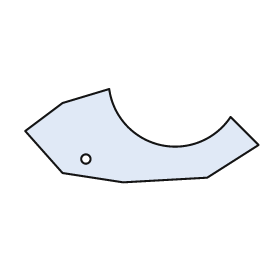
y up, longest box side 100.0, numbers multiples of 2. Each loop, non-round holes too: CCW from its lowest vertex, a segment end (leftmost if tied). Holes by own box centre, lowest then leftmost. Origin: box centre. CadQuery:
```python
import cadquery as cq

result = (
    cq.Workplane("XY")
    .moveTo(-8.0, -20.0)
    .lineTo(28.0, -18.0)
    .lineTo(50.0, -4.0)
    .lineTo(38.0, 8.0)
    .threePointArc((8.0, -4.0), (-14.0, 20.0))
    .lineTo(-34.0, 14.0)
    .lineTo(-50.0, 2.0)
    .lineTo(-34.0, -16.0)
    .close()
    .moveTo(-24.0, -10.0)
    .circle(2.0)
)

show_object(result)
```